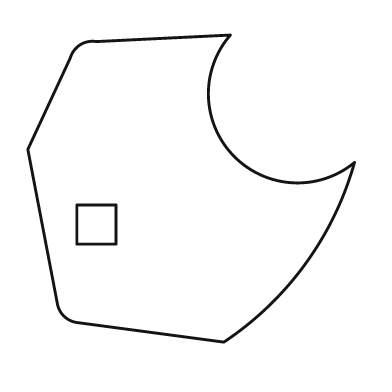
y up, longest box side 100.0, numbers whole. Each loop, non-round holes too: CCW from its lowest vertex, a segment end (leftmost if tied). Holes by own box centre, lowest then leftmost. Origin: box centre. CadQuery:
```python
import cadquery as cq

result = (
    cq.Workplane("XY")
    .moveTo(10.0, -47.0)
    .threePointArc((35.0, -23.0), (50.0, 8.0))
    .threePointArc((13.0, 10.0), (12.0, 47.0))
    .lineTo(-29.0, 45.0)
    .threePointArc((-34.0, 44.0), (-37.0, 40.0))
    .lineTo(-50.0, 12.0)
    .lineTo(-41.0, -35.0)
    .threePointArc((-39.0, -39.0), (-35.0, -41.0))
    .close()
    .moveTo(-35.0, -17.0)
    .lineTo(-23.0, -17.0)
    .lineTo(-23.0, -5.0)
    .lineTo(-35.0, -5.0)
    .close()
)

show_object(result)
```